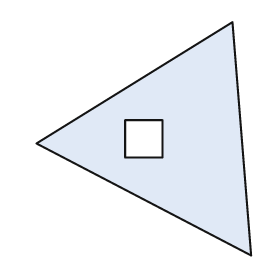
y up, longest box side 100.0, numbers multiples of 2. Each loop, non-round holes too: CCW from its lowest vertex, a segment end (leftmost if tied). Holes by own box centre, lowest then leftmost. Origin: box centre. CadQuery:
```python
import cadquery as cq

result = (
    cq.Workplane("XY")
    .moveTo(46.0, -50.0)
    .lineTo(38.0, 50.0)
    .lineTo(-46.0, -2.0)
    .close()
    .moveTo(-8.0, -8.0)
    .lineTo(8.0, -8.0)
    .lineTo(8.0, 8.0)
    .lineTo(-8.0, 8.0)
    .close()
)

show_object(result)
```